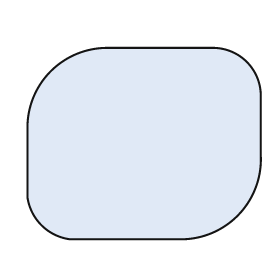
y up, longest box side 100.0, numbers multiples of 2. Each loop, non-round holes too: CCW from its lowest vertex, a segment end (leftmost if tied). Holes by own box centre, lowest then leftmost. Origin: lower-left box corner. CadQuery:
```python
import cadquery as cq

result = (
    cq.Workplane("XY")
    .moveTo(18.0, 0.0)
    .lineTo(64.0, 0.0)
    .threePointArc((90.0, 10.0), (100.0, 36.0))
    .lineTo(100.0, 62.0)
    .threePointArc((94.0, 76.0), (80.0, 82.0))
    .lineTo(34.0, 82.0)
    .threePointArc((10.0, 72.0), (0.0, 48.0))
    .lineTo(0.0, 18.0)
    .threePointArc((6.0, 6.0), (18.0, 0.0))
    .close()
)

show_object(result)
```